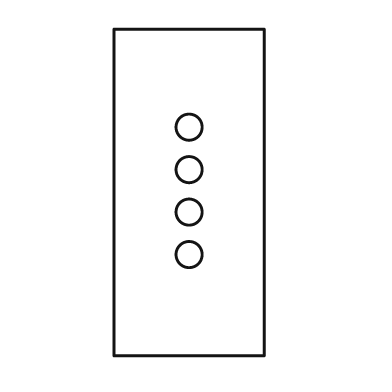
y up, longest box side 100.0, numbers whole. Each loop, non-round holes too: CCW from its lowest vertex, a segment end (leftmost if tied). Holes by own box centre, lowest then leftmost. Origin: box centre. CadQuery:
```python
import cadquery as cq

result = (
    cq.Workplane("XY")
    .moveTo(-23.0, -50.0)
    .lineTo(23.0, -50.0)
    .lineTo(23.0, 50.0)
    .lineTo(-23.0, 50.0)
    .close()
    .moveTo(0.0, -19.0)
    .circle(4.0)
    .moveTo(0.0, -6.0)
    .circle(4.0)
    .moveTo(0.0, 7.0)
    .circle(4.0)
    .moveTo(0.0, 20.0)
    .circle(4.0)
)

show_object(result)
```